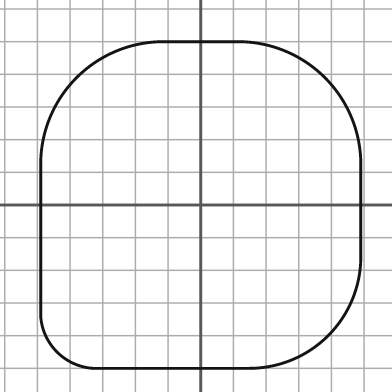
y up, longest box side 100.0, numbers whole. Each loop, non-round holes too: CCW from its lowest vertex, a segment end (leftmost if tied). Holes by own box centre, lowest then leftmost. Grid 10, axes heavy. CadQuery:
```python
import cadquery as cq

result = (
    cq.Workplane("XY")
    .moveTo(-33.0, -50.0)
    .lineTo(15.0, -50.0)
    .threePointArc((39.0, -40.0), (49.0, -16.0))
    .lineTo(49.0, 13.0)
    .threePointArc((38.0, 39.0), (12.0, 50.0))
    .lineTo(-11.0, 50.0)
    .threePointArc((-38.0, 39.0), (-49.0, 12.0))
    .lineTo(-49.0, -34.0)
    .threePointArc((-44.0, -45.0), (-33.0, -50.0))
    .close()
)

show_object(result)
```